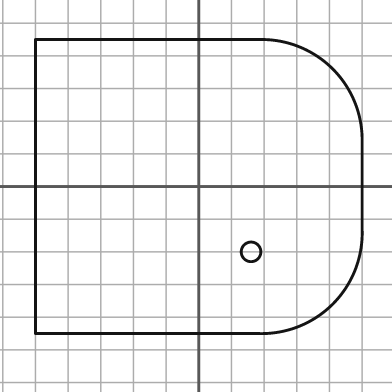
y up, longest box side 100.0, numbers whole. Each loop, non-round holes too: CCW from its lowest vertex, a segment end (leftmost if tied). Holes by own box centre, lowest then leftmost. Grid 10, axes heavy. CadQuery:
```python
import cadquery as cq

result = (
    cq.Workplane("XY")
    .moveTo(-50.0, -45.0)
    .lineTo(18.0, -45.0)
    .threePointArc((41.0, -36.0), (50.0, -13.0))
    .lineTo(50.0, 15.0)
    .threePointArc((41.0, 36.0), (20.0, 45.0))
    .lineTo(-50.0, 45.0)
    .close()
    .moveTo(16.0, -20.0)
    .circle(3.0)
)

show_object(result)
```